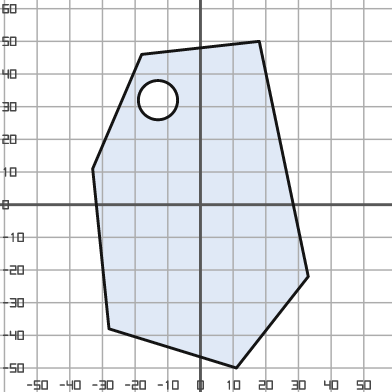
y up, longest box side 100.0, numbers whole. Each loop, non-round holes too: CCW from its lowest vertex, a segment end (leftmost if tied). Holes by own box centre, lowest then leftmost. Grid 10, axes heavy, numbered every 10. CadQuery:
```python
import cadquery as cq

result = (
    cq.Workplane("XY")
    .moveTo(11.0, -50.0)
    .lineTo(33.0, -22.0)
    .lineTo(18.0, 50.0)
    .lineTo(-18.0, 46.0)
    .lineTo(-33.0, 11.0)
    .lineTo(-28.0, -38.0)
    .close()
    .moveTo(-13.0, 32.0)
    .circle(6.0)
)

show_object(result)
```